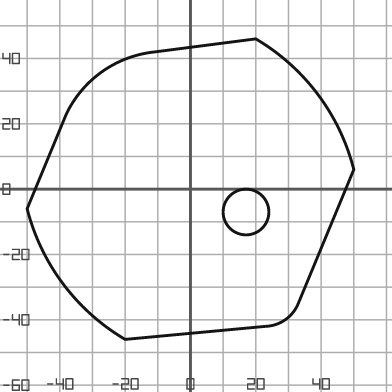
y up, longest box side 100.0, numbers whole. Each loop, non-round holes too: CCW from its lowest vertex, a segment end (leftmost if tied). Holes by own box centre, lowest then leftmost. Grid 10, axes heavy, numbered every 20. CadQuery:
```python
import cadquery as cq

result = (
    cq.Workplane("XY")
    .moveTo(-20.0, -46.0)
    .lineTo(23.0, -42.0)
    .threePointArc((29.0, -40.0), (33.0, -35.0))
    .lineTo(50.0, 6.0)
    .threePointArc((39.0, 29.0), (20.0, 46.0))
    .lineTo(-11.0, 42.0)
    .threePointArc((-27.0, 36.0), (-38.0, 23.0))
    .lineTo(-50.0, -6.0)
    .threePointArc((-39.0, -29.0), (-20.0, -46.0))
    .close()
    .moveTo(17.0, -7.0)
    .circle(7.0)
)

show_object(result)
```